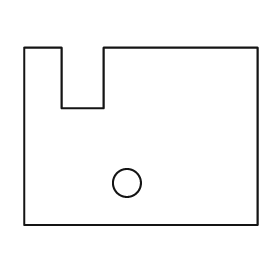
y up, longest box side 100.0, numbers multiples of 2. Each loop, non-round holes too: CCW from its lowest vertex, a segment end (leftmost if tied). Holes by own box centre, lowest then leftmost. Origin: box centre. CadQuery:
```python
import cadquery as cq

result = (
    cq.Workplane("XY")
    .moveTo(-50.0, -38.0)
    .lineTo(50.0, -38.0)
    .lineTo(50.0, 38.0)
    .lineTo(-16.0, 38.0)
    .lineTo(-16.0, 12.0)
    .lineTo(-34.0, 12.0)
    .lineTo(-34.0, 38.0)
    .lineTo(-50.0, 38.0)
    .close()
    .moveTo(-6.0, -20.0)
    .circle(6.0)
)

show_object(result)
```